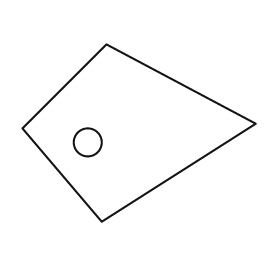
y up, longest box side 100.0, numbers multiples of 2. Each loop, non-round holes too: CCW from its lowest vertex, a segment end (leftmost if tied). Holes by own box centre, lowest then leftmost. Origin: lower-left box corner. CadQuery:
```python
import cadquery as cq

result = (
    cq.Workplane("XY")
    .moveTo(34.0, 0.0)
    .lineTo(100.0, 42.0)
    .lineTo(36.0, 76.0)
    .lineTo(0.0, 40.0)
    .close()
    .moveTo(28.0, 34.0)
    .circle(6.0)
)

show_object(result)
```